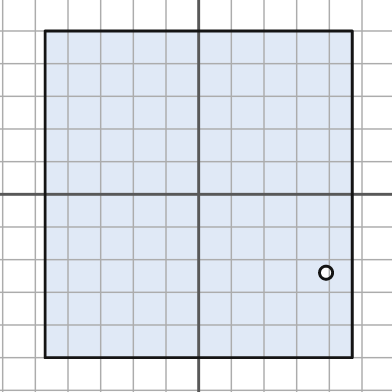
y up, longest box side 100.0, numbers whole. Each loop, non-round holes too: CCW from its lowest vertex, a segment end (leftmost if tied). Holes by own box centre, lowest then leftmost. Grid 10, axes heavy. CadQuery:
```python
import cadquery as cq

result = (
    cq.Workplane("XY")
    .moveTo(-47.0, -50.0)
    .lineTo(47.0, -50.0)
    .lineTo(47.0, 50.0)
    .lineTo(-47.0, 50.0)
    .close()
    .moveTo(39.0, -24.0)
    .circle(2.0)
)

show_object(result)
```